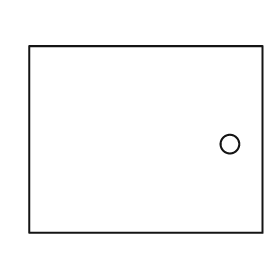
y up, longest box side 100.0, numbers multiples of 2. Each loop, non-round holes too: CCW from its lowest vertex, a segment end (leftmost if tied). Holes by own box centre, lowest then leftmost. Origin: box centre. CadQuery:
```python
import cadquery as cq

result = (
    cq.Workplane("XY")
    .moveTo(-50.0, -40.0)
    .lineTo(50.0, -40.0)
    .lineTo(50.0, 40.0)
    .lineTo(-50.0, 40.0)
    .close()
    .moveTo(36.0, -2.0)
    .circle(4.0)
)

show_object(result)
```